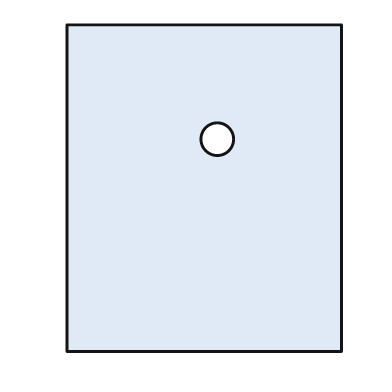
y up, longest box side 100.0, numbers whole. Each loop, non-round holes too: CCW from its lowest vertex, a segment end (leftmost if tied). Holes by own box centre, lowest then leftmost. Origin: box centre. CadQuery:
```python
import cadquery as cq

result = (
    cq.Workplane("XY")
    .moveTo(-42.0, -50.0)
    .lineTo(42.0, -50.0)
    .lineTo(42.0, 50.0)
    .lineTo(-42.0, 50.0)
    .close()
    .moveTo(4.0, 15.0)
    .circle(5.0)
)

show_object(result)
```